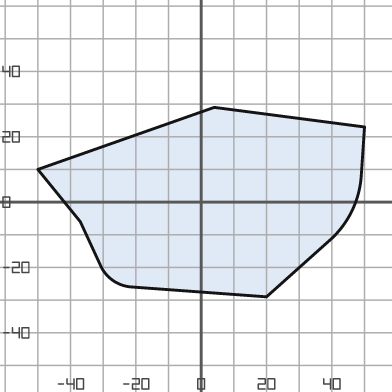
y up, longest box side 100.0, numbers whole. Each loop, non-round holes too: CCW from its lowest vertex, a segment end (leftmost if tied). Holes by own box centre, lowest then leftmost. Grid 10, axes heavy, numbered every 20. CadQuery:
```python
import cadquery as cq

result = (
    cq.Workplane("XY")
    .moveTo(20.0, -29.0)
    .lineTo(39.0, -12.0)
    .threePointArc((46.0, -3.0), (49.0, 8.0))
    .lineTo(50.0, 23.0)
    .lineTo(4.0, 29.0)
    .lineTo(-50.0, 10.0)
    .lineTo(-37.0, -6.0)
    .lineTo(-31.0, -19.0)
    .threePointArc((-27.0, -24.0), (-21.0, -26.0))
    .close()
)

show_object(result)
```